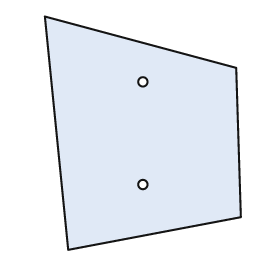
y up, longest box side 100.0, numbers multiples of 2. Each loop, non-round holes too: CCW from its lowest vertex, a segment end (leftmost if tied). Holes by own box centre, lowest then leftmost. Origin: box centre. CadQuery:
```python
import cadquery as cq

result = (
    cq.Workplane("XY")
    .moveTo(-32.0, -50.0)
    .lineTo(42.0, -36.0)
    .lineTo(40.0, 28.0)
    .lineTo(-42.0, 50.0)
    .close()
    .moveTo(0.0, -22.0)
    .circle(2.0)
    .moveTo(0.0, 22.0)
    .circle(2.0)
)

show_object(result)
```